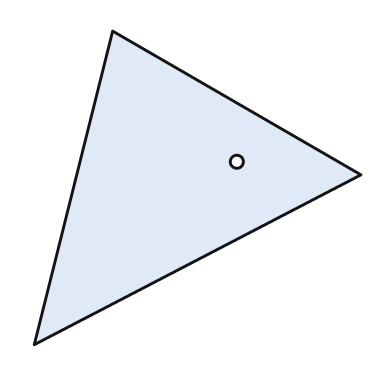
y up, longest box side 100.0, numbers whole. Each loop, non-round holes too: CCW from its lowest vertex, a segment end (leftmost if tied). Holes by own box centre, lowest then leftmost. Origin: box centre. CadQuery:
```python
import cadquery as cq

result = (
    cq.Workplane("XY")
    .moveTo(-50.0, -48.0)
    .lineTo(50.0, 4.0)
    .lineTo(-26.0, 48.0)
    .close()
    .moveTo(12.0, 8.0)
    .circle(2.0)
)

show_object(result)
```